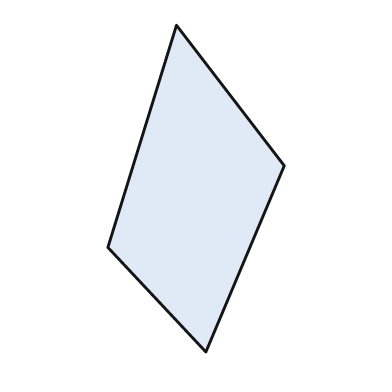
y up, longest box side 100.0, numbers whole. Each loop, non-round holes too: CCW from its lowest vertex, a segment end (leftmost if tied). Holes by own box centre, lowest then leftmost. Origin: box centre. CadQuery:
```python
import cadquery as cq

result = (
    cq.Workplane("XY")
    .moveTo(3.0, -50.0)
    .lineTo(27.0, 7.0)
    .lineTo(-6.0, 50.0)
    .lineTo(-27.0, -18.0)
    .close()
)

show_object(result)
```